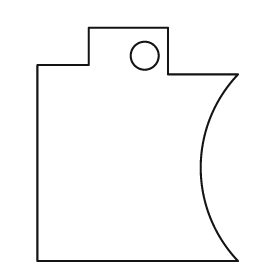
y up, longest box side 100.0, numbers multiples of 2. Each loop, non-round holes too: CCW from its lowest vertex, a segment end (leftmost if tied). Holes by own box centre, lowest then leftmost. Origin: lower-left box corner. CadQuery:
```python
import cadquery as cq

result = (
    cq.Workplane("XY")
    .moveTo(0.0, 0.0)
    .lineTo(86.0, 0.0)
    .threePointArc((70.0, 40.0), (86.0, 80.0))
    .lineTo(56.0, 80.0)
    .lineTo(56.0, 100.0)
    .lineTo(22.0, 100.0)
    .lineTo(22.0, 84.0)
    .lineTo(0.0, 84.0)
    .close()
    .moveTo(46.0, 88.0)
    .circle(6.0)
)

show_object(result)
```